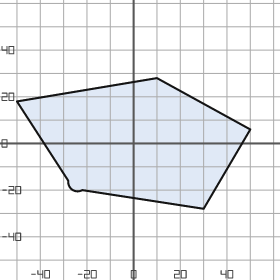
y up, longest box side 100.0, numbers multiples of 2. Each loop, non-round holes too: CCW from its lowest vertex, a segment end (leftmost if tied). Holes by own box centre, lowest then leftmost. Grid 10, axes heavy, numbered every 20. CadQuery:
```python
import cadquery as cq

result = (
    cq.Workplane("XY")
    .moveTo(30.0, -28.0)
    .lineTo(50.0, 6.0)
    .lineTo(10.0, 28.0)
    .lineTo(-50.0, 18.0)
    .lineTo(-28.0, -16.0)
    .threePointArc((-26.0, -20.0), (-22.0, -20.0))
    .close()
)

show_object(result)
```